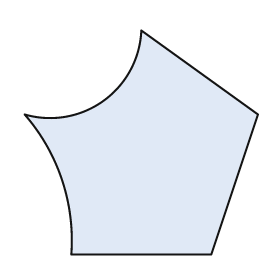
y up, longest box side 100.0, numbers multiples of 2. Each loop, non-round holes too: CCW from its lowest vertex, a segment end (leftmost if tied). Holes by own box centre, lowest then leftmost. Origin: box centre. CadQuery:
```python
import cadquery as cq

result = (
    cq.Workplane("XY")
    .moveTo(-30.0, -48.0)
    .lineTo(30.0, -48.0)
    .lineTo(50.0, 12.0)
    .lineTo(0.0, 48.0)
    .threePointArc((-16.0, 18.0), (-50.0, 12.0))
    .threePointArc((-34.0, -16.0), (-30.0, -48.0))
    .close()
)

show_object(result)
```